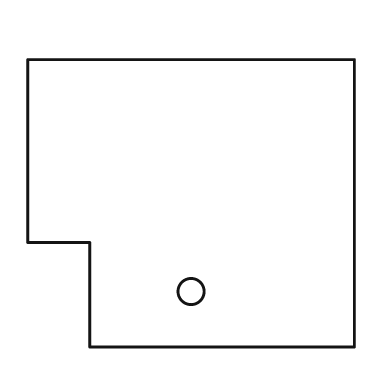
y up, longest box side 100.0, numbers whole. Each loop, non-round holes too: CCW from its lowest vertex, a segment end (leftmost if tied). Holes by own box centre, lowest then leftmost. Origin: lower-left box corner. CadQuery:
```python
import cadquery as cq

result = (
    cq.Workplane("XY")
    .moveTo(19.0, 0.0)
    .lineTo(100.0, 0.0)
    .lineTo(100.0, 88.0)
    .lineTo(0.0, 88.0)
    .lineTo(0.0, 32.0)
    .lineTo(19.0, 32.0)
    .close()
    .moveTo(50.0, 17.0)
    .circle(4.0)
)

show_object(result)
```